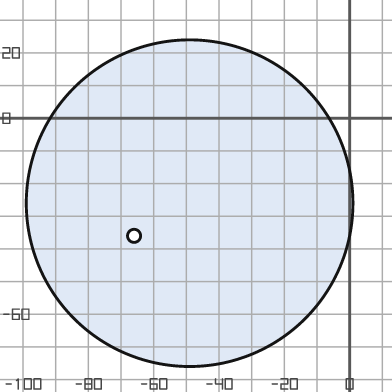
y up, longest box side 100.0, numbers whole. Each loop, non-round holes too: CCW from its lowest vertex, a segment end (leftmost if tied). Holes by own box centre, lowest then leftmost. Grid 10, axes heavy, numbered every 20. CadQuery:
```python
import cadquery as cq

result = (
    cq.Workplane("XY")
    .moveTo(-49.0, -26.0)
    .circle(50.0)
    .moveTo(-66.0, -36.0)
    .circle(2.0)
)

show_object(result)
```